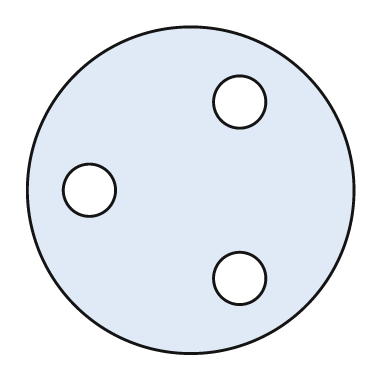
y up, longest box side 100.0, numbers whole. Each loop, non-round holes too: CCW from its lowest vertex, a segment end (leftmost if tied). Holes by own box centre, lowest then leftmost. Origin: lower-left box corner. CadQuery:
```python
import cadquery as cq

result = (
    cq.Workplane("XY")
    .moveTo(50.0, 50.0)
    .circle(50.0)
    .moveTo(65.0, 23.0)
    .circle(8.0)
    .moveTo(19.0, 50.0)
    .circle(8.0)
    .moveTo(65.0, 77.0)
    .circle(8.0)
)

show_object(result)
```